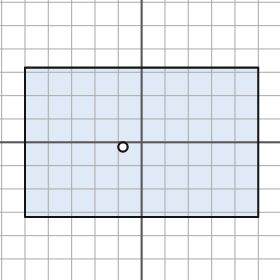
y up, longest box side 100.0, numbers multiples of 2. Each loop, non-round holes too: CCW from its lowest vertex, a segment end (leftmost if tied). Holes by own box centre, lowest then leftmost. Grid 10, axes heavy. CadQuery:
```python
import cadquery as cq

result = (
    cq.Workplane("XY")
    .moveTo(-50.0, -32.0)
    .lineTo(50.0, -32.0)
    .lineTo(50.0, 32.0)
    .lineTo(-50.0, 32.0)
    .close()
    .moveTo(-8.0, -2.0)
    .circle(2.0)
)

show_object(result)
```